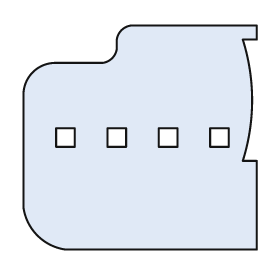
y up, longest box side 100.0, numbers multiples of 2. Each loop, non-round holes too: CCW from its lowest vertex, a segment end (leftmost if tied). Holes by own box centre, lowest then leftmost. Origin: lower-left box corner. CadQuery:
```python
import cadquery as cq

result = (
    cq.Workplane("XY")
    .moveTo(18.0, 0.0)
    .lineTo(100.0, 0.0)
    .lineTo(100.0, 38.0)
    .lineTo(94.0, 38.0)
    .threePointArc((98.0, 64.0), (94.0, 90.0))
    .lineTo(100.0, 90.0)
    .lineTo(100.0, 96.0)
    .lineTo(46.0, 96.0)
    .threePointArc((42.0, 94.0), (40.0, 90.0))
    .lineTo(40.0, 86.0)
    .threePointArc((38.0, 82.0), (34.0, 80.0))
    .lineTo(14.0, 80.0)
    .threePointArc((4.0, 76.0), (0.0, 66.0))
    .lineTo(0.0, 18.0)
    .threePointArc((6.0, 6.0), (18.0, 0.0))
    .close()
    .moveTo(14.0, 44.0)
    .lineTo(22.0, 44.0)
    .lineTo(22.0, 52.0)
    .lineTo(14.0, 52.0)
    .close()
    .moveTo(36.0, 44.0)
    .lineTo(44.0, 44.0)
    .lineTo(44.0, 52.0)
    .lineTo(36.0, 52.0)
    .close()
    .moveTo(58.0, 44.0)
    .lineTo(66.0, 44.0)
    .lineTo(66.0, 52.0)
    .lineTo(58.0, 52.0)
    .close()
    .moveTo(80.0, 44.0)
    .lineTo(88.0, 44.0)
    .lineTo(88.0, 52.0)
    .lineTo(80.0, 52.0)
    .close()
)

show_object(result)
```